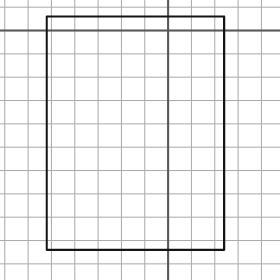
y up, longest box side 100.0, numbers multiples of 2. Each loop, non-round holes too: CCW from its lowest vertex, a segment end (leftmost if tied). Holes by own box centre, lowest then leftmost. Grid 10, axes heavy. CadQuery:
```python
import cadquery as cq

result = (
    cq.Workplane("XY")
    .moveTo(-52.0, -94.0)
    .lineTo(24.0, -94.0)
    .lineTo(24.0, 6.0)
    .lineTo(-52.0, 6.0)
    .close()
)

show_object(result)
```